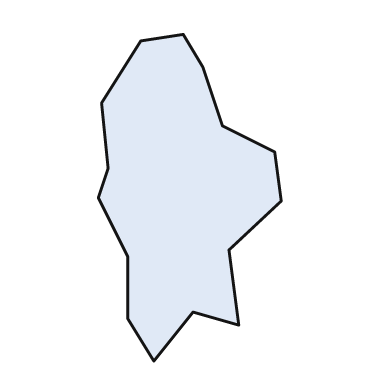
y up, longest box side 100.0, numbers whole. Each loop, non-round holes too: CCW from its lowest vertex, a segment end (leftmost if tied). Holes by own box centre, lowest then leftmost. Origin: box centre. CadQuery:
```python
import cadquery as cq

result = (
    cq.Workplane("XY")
    .moveTo(-11.0, -50.0)
    .lineTo(1.0, -35.0)
    .lineTo(15.0, -39.0)
    .lineTo(12.0, -16.0)
    .lineTo(28.0, -1.0)
    .lineTo(26.0, 14.0)
    .lineTo(10.0, 22.0)
    .lineTo(4.0, 40.0)
    .lineTo(-2.0, 50.0)
    .lineTo(-15.0, 48.0)
    .lineTo(-27.0, 29.0)
    .lineTo(-25.0, 9.0)
    .lineTo(-28.0, 0.0)
    .lineTo(-19.0, -18.0)
    .lineTo(-19.0, -37.0)
    .close()
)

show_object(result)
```